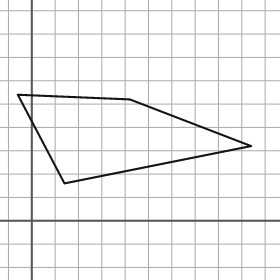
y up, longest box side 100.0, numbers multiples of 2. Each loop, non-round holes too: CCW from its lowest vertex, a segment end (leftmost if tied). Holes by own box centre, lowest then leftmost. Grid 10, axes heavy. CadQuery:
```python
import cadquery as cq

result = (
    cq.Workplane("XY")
    .moveTo(14.0, 16.0)
    .lineTo(94.0, 32.0)
    .lineTo(42.0, 52.0)
    .lineTo(-6.0, 54.0)
    .close()
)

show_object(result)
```